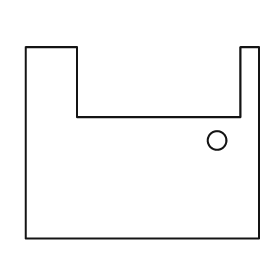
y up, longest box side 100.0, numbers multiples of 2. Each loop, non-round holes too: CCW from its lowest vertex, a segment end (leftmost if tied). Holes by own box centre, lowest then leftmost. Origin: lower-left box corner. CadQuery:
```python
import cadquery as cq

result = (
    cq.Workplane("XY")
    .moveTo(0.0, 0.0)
    .lineTo(100.0, 0.0)
    .lineTo(100.0, 82.0)
    .lineTo(92.0, 82.0)
    .lineTo(92.0, 52.0)
    .lineTo(22.0, 52.0)
    .lineTo(22.0, 82.0)
    .lineTo(0.0, 82.0)
    .close()
    .moveTo(82.0, 42.0)
    .circle(4.0)
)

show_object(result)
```